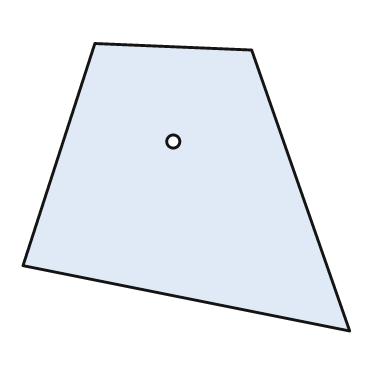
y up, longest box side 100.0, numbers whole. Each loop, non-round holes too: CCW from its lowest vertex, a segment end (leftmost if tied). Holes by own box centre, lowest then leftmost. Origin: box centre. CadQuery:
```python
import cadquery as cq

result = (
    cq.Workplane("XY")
    .moveTo(50.0, -44.0)
    .lineTo(20.0, 42.0)
    .lineTo(-28.0, 44.0)
    .lineTo(-50.0, -24.0)
    .close()
    .moveTo(-4.0, 14.0)
    .circle(2.0)
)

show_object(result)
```